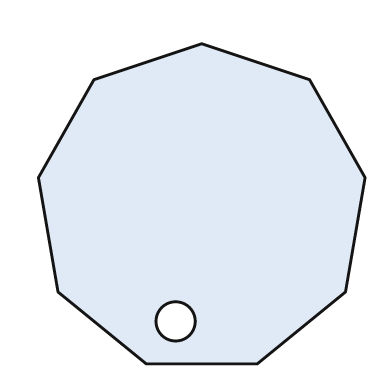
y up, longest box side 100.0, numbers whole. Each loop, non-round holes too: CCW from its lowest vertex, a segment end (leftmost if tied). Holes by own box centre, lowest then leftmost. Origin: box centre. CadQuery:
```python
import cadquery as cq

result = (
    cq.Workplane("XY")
    .moveTo(-17.0, -49.0)
    .lineTo(17.0, -49.0)
    .lineTo(44.0, -27.0)
    .lineTo(50.0, 8.0)
    .lineTo(33.0, 38.0)
    .lineTo(0.0, 49.0)
    .lineTo(-33.0, 38.0)
    .lineTo(-50.0, 8.0)
    .lineTo(-44.0, -27.0)
    .close()
    .moveTo(-8.0, -36.0)
    .circle(6.0)
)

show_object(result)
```